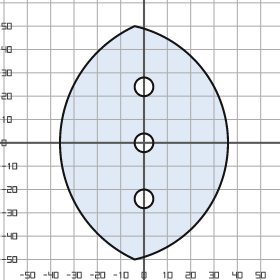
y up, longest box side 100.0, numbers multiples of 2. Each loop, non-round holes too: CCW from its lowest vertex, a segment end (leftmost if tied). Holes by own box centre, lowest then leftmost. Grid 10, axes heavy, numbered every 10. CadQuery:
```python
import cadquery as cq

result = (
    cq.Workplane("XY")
    .moveTo(-4.0, -50.0)
    .threePointArc((36.0, 0.0), (-4.0, 50.0))
    .threePointArc((-36.0, 0.0), (-4.0, -50.0))
    .close()
    .moveTo(0.0, -24.0)
    .circle(4.0)
    .moveTo(0.0, 0.0)
    .circle(4.0)
    .moveTo(0.0, 24.0)
    .circle(4.0)
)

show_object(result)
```